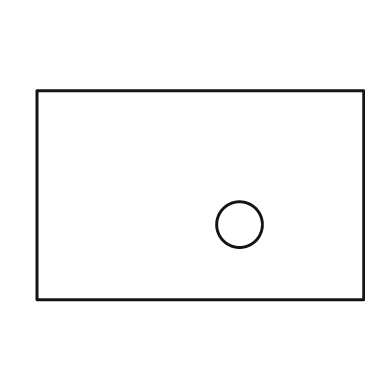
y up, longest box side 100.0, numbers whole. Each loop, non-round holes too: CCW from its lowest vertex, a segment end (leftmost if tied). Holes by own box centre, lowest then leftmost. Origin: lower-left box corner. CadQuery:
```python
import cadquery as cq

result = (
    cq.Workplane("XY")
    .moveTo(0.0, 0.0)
    .lineTo(100.0, 0.0)
    .lineTo(100.0, 64.0)
    .lineTo(0.0, 64.0)
    .close()
    .moveTo(62.0, 23.0)
    .circle(7.0)
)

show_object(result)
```